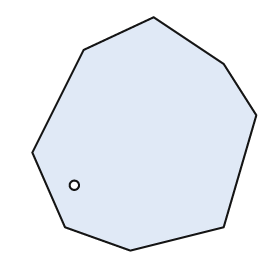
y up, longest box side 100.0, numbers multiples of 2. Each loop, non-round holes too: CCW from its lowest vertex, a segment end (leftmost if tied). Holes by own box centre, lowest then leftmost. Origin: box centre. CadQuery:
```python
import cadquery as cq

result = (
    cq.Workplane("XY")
    .moveTo(-6.0, -50.0)
    .lineTo(34.0, -40.0)
    .lineTo(48.0, 8.0)
    .lineTo(34.0, 30.0)
    .lineTo(4.0, 50.0)
    .lineTo(-26.0, 36.0)
    .lineTo(-48.0, -8.0)
    .lineTo(-34.0, -40.0)
    .close()
    .moveTo(-30.0, -22.0)
    .circle(2.0)
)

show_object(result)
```